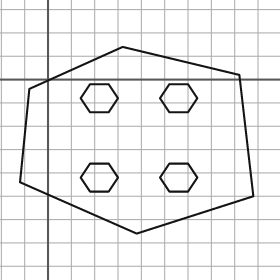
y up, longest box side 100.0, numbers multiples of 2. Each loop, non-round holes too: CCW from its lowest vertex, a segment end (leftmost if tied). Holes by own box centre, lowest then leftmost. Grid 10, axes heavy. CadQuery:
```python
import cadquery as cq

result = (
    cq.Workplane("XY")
    .moveTo(38.0, -66.0)
    .lineTo(88.0, -50.0)
    .lineTo(82.0, 2.0)
    .lineTo(32.0, 14.0)
    .lineTo(-8.0, -4.0)
    .lineTo(-12.0, -44.0)
    .close()
    .moveTo(18.0, -48.0)
    .lineTo(26.0, -48.0)
    .lineTo(30.0, -42.0)
    .lineTo(26.0, -36.0)
    .lineTo(18.0, -36.0)
    .lineTo(14.0, -42.0)
    .close()
    .moveTo(52.0, -48.0)
    .lineTo(60.0, -48.0)
    .lineTo(64.0, -42.0)
    .lineTo(60.0, -36.0)
    .lineTo(52.0, -36.0)
    .lineTo(48.0, -42.0)
    .close()
    .moveTo(18.0, -14.0)
    .lineTo(26.0, -14.0)
    .lineTo(30.0, -8.0)
    .lineTo(26.0, -2.0)
    .lineTo(18.0, -2.0)
    .lineTo(14.0, -8.0)
    .close()
    .moveTo(52.0, -14.0)
    .lineTo(60.0, -14.0)
    .lineTo(64.0, -8.0)
    .lineTo(60.0, -2.0)
    .lineTo(52.0, -2.0)
    .lineTo(48.0, -8.0)
    .close()
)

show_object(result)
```